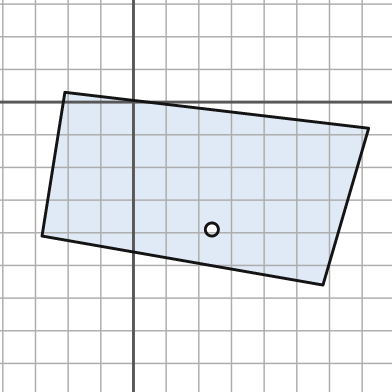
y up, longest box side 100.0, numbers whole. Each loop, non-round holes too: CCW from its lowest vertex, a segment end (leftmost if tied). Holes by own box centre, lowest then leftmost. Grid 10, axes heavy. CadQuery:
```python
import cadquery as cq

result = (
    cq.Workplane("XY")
    .moveTo(58.0, -56.0)
    .lineTo(72.0, -8.0)
    .lineTo(-21.0, 3.0)
    .lineTo(-28.0, -41.0)
    .close()
    .moveTo(24.0, -39.0)
    .circle(2.0)
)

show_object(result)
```